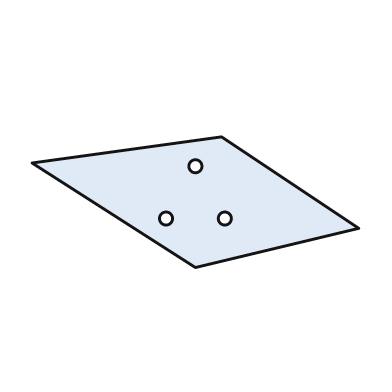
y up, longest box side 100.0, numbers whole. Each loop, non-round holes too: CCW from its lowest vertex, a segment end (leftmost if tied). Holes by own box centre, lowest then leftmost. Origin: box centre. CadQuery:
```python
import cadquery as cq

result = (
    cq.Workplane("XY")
    .moveTo(0.0, -20.0)
    .lineTo(50.0, -8.0)
    .lineTo(8.0, 20.0)
    .lineTo(-50.0, 12.0)
    .close()
    .moveTo(-9.0, -5.0)
    .circle(2.0)
    .moveTo(9.0, -5.0)
    .circle(2.0)
    .moveTo(0.0, 11.0)
    .circle(2.0)
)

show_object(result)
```